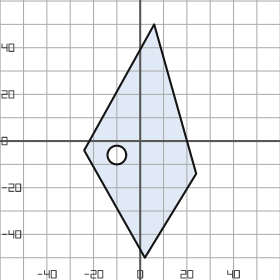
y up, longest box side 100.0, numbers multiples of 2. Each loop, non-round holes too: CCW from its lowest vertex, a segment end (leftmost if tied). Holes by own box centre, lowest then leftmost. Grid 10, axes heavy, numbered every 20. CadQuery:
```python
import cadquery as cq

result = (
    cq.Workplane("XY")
    .moveTo(2.0, -50.0)
    .lineTo(24.0, -14.0)
    .lineTo(6.0, 50.0)
    .lineTo(-24.0, -4.0)
    .close()
    .moveTo(-10.0, -6.0)
    .circle(4.0)
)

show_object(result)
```